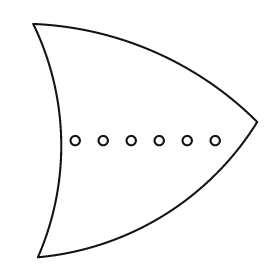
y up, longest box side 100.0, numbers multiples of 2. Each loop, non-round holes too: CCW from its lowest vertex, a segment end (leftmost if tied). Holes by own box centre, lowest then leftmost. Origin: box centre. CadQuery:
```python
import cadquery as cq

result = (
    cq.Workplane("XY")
    .moveTo(-46.0, -50.0)
    .threePointArc((8.0, -32.0), (48.0, 8.0))
    .threePointArc((4.0, 38.0), (-48.0, 50.0))
    .threePointArc((-36.0, 0.0), (-46.0, -50.0))
    .close()
    .moveTo(-30.0, 0.0)
    .circle(2.0)
    .moveTo(-18.0, 0.0)
    .circle(2.0)
    .moveTo(-6.0, 0.0)
    .circle(2.0)
    .moveTo(6.0, 0.0)
    .circle(2.0)
    .moveTo(18.0, 0.0)
    .circle(2.0)
    .moveTo(30.0, 0.0)
    .circle(2.0)
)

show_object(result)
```